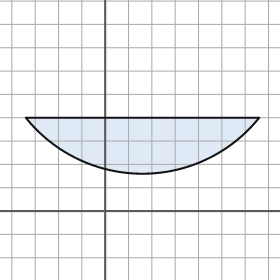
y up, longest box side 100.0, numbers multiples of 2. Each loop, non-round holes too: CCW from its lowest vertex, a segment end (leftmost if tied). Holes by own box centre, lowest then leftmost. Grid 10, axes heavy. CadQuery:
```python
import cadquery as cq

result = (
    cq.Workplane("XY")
    .moveTo(-34.0, 40.0)
    .threePointArc((16.0, 16.0), (66.0, 40.0))
    .close()
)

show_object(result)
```